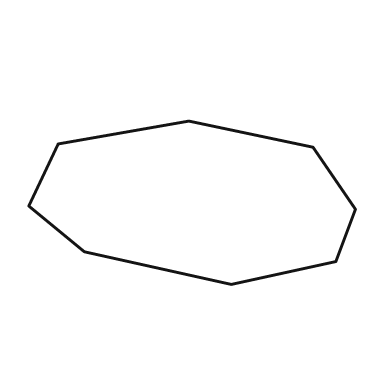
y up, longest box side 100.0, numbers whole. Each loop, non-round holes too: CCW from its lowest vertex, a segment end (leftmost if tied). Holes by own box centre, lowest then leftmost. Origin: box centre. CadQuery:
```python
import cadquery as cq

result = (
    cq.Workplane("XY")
    .moveTo(12.0, -25.0)
    .lineTo(44.0, -18.0)
    .lineTo(50.0, -2.0)
    .lineTo(37.0, 17.0)
    .lineTo(-1.0, 25.0)
    .lineTo(-41.0, 18.0)
    .lineTo(-50.0, -1.0)
    .lineTo(-33.0, -15.0)
    .close()
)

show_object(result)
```